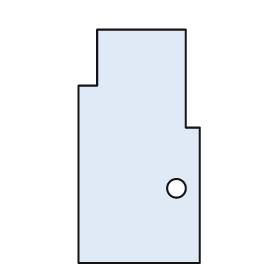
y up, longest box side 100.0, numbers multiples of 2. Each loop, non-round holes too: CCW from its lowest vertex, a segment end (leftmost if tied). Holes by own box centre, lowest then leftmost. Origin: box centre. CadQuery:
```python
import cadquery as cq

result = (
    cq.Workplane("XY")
    .moveTo(-26.0, -50.0)
    .lineTo(26.0, -50.0)
    .lineTo(26.0, 8.0)
    .lineTo(20.0, 8.0)
    .lineTo(20.0, 50.0)
    .lineTo(-18.0, 50.0)
    .lineTo(-18.0, 26.0)
    .lineTo(-26.0, 26.0)
    .close()
    .moveTo(16.0, -18.0)
    .circle(4.0)
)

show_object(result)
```